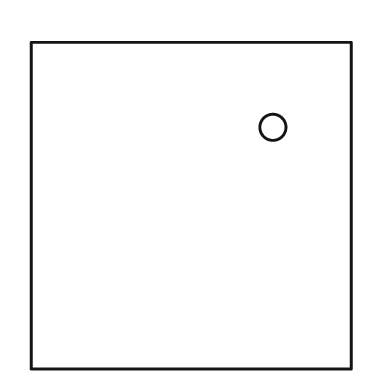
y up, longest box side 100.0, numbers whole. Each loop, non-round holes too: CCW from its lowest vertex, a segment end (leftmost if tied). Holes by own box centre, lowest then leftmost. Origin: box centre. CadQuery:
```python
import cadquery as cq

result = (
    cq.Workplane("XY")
    .moveTo(-49.0, -50.0)
    .lineTo(49.0, -50.0)
    .lineTo(49.0, 50.0)
    .lineTo(-49.0, 50.0)
    .close()
    .moveTo(25.0, 24.0)
    .circle(4.0)
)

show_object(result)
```